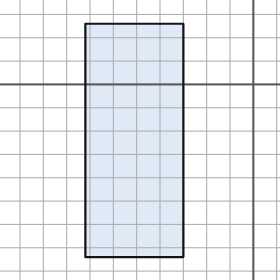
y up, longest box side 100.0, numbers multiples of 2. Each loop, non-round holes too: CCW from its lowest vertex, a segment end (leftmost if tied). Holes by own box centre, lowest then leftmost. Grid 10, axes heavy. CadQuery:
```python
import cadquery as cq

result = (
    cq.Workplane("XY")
    .moveTo(-72.0, -74.0)
    .lineTo(-30.0, -74.0)
    .lineTo(-30.0, 26.0)
    .lineTo(-72.0, 26.0)
    .close()
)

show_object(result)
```